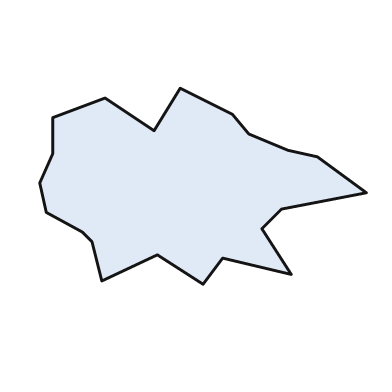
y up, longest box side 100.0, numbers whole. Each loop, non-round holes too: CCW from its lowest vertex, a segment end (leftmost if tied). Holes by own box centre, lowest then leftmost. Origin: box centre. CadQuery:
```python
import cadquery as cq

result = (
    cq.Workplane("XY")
    .moveTo(0.0, -30.0)
    .lineTo(6.0, -22.0)
    .lineTo(27.0, -27.0)
    .lineTo(18.0, -13.0)
    .lineTo(24.0, -7.0)
    .lineTo(50.0, -2.0)
    .lineTo(35.0, 9.0)
    .lineTo(26.0, 11.0)
    .lineTo(14.0, 16.0)
    .lineTo(9.0, 22.0)
    .lineTo(-7.0, 30.0)
    .lineTo(-15.0, 17.0)
    .lineTo(-30.0, 27.0)
    .lineTo(-46.0, 21.0)
    .lineTo(-46.0, 10.0)
    .lineTo(-50.0, 1.0)
    .lineTo(-48.0, -8.0)
    .lineTo(-37.0, -14.0)
    .lineTo(-34.0, -17.0)
    .lineTo(-31.0, -29.0)
    .lineTo(-14.0, -21.0)
    .close()
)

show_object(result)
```